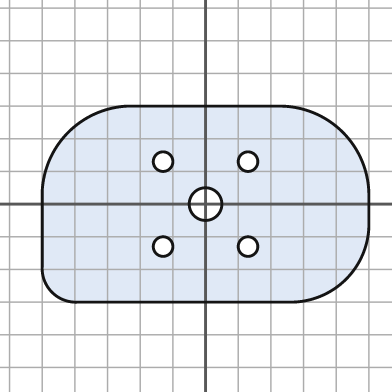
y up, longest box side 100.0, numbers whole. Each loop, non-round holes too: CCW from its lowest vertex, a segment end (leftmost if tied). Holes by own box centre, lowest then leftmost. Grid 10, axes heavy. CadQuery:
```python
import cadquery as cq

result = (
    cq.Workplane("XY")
    .moveTo(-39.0, -30.0)
    .lineTo(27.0, -30.0)
    .threePointArc((43.0, -23.0), (50.0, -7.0))
    .lineTo(50.0, 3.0)
    .threePointArc((42.0, 22.0), (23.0, 30.0))
    .lineTo(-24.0, 30.0)
    .threePointArc((-42.0, 22.0), (-50.0, 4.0))
    .lineTo(-50.0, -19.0)
    .threePointArc((-47.0, -27.0), (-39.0, -30.0))
    .close()
    .moveTo(-13.0, -13.0)
    .circle(3.0)
    .moveTo(13.0, -13.0)
    .circle(3.0)
    .moveTo(0.0, 0.0)
    .circle(5.0)
    .moveTo(-13.0, 13.0)
    .circle(3.0)
    .moveTo(13.0, 13.0)
    .circle(3.0)
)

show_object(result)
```